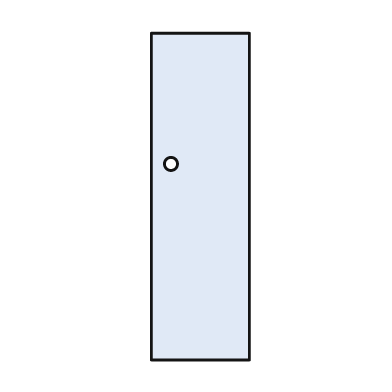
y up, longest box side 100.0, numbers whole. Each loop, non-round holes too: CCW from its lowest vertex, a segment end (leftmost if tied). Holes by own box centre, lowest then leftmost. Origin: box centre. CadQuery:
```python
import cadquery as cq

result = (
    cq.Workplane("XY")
    .moveTo(-15.0, -50.0)
    .lineTo(15.0, -50.0)
    .lineTo(15.0, 50.0)
    .lineTo(-15.0, 50.0)
    .close()
    .moveTo(-9.0, 10.0)
    .circle(2.0)
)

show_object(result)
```